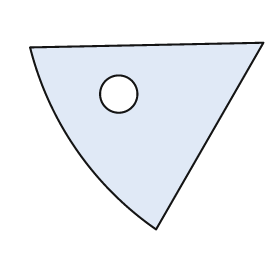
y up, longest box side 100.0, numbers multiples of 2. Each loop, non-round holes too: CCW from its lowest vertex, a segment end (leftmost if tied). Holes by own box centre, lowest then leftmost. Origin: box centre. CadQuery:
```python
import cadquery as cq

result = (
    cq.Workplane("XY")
    .moveTo(4.0, -40.0)
    .lineTo(50.0, 40.0)
    .lineTo(-50.0, 38.0)
    .threePointArc((-30.0, -6.0), (4.0, -40.0))
    .close()
    .moveTo(-12.0, 18.0)
    .circle(8.0)
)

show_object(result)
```